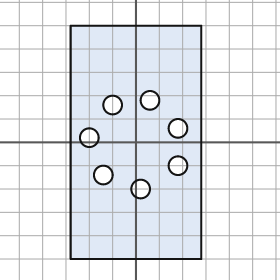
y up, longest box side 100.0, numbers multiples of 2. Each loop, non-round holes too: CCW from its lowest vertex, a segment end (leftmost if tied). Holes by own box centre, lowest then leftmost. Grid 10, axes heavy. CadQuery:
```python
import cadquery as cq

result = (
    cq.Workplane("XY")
    .moveTo(-28.0, -50.0)
    .lineTo(28.0, -50.0)
    .lineTo(28.0, 50.0)
    .lineTo(-28.0, 50.0)
    .close()
    .moveTo(2.0, -20.0)
    .circle(4.0)
    .moveTo(-14.0, -14.0)
    .circle(4.0)
    .moveTo(18.0, -10.0)
    .circle(4.0)
    .moveTo(-20.0, 2.0)
    .circle(4.0)
    .moveTo(18.0, 6.0)
    .circle(4.0)
    .moveTo(-10.0, 16.0)
    .circle(4.0)
    .moveTo(6.0, 18.0)
    .circle(4.0)
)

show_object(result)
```